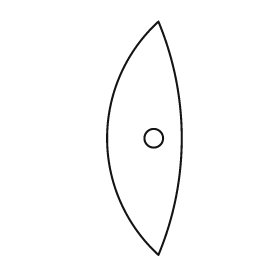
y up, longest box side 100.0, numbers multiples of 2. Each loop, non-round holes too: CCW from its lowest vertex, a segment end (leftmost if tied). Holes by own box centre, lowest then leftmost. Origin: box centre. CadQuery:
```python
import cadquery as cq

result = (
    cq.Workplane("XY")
    .moveTo(6.0, -50.0)
    .threePointArc((16.0, 0.0), (6.0, 50.0))
    .threePointArc((-16.0, 0.0), (6.0, -50.0))
    .close()
    .moveTo(4.0, 0.0)
    .circle(4.0)
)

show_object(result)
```